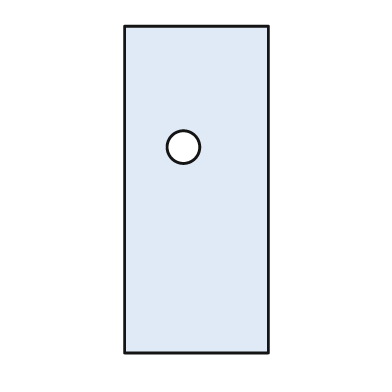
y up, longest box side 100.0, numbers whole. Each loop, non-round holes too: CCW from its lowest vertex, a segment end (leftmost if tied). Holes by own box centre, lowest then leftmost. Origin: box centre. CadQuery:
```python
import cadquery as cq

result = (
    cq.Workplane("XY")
    .moveTo(-22.0, -50.0)
    .lineTo(22.0, -50.0)
    .lineTo(22.0, 50.0)
    .lineTo(-22.0, 50.0)
    .close()
    .moveTo(-4.0, 13.0)
    .circle(5.0)
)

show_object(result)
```